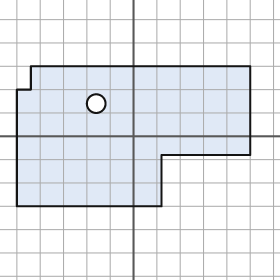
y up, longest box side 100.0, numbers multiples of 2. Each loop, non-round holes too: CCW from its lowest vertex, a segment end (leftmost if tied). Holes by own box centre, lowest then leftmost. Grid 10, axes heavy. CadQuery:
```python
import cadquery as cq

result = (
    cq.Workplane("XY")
    .moveTo(-50.0, -30.0)
    .lineTo(12.0, -30.0)
    .lineTo(12.0, -8.0)
    .lineTo(50.0, -8.0)
    .lineTo(50.0, 30.0)
    .lineTo(-44.0, 30.0)
    .lineTo(-44.0, 20.0)
    .lineTo(-50.0, 20.0)
    .close()
    .moveTo(-16.0, 14.0)
    .circle(4.0)
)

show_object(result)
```